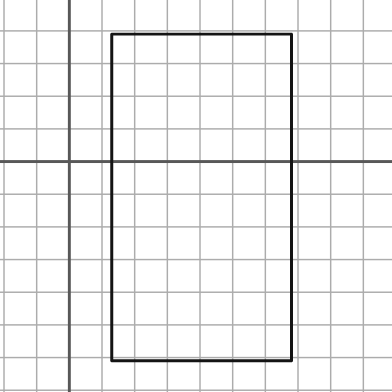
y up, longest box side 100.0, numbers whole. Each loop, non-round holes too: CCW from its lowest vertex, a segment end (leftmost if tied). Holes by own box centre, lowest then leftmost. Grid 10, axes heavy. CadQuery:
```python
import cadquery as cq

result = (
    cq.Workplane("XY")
    .moveTo(13.0, -61.0)
    .lineTo(68.0, -61.0)
    .lineTo(68.0, 39.0)
    .lineTo(13.0, 39.0)
    .close()
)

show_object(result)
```